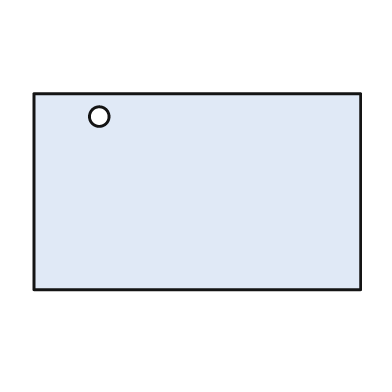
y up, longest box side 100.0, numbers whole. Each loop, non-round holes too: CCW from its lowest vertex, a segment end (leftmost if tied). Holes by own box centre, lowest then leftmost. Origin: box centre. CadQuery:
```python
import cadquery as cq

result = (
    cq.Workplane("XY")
    .moveTo(-50.0, -30.0)
    .lineTo(50.0, -30.0)
    .lineTo(50.0, 30.0)
    .lineTo(-50.0, 30.0)
    .close()
    .moveTo(-30.0, 23.0)
    .circle(3.0)
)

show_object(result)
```